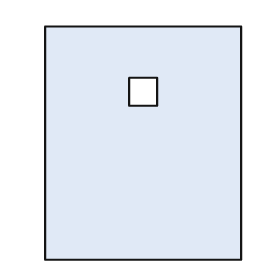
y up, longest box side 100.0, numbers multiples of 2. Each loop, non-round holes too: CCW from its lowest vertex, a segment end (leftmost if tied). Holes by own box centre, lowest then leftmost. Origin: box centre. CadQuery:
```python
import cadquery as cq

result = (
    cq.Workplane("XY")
    .moveTo(-42.0, -50.0)
    .lineTo(42.0, -50.0)
    .lineTo(42.0, 50.0)
    .lineTo(-42.0, 50.0)
    .close()
    .moveTo(-6.0, 16.0)
    .lineTo(6.0, 16.0)
    .lineTo(6.0, 28.0)
    .lineTo(-6.0, 28.0)
    .close()
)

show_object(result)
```